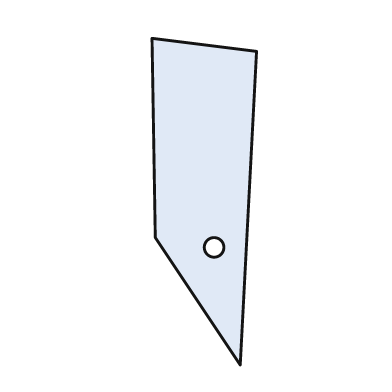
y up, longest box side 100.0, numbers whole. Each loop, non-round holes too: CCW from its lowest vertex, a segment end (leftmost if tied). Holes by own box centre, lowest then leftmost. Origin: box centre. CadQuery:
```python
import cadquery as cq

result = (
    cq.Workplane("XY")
    .moveTo(11.0, -50.0)
    .lineTo(16.0, 46.0)
    .lineTo(-16.0, 50.0)
    .lineTo(-15.0, -11.0)
    .close()
    .moveTo(3.0, -14.0)
    .circle(3.0)
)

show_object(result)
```